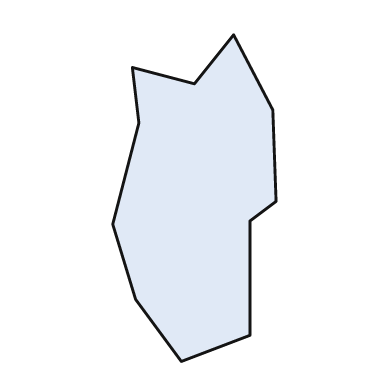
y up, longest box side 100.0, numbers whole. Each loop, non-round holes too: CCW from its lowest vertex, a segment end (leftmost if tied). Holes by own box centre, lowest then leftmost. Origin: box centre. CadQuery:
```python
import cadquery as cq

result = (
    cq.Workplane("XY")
    .moveTo(-4.0, -50.0)
    .lineTo(17.0, -42.0)
    .lineTo(17.0, -7.0)
    .lineTo(25.0, -1.0)
    .lineTo(24.0, 27.0)
    .lineTo(12.0, 50.0)
    .lineTo(0.0, 35.0)
    .lineTo(-19.0, 40.0)
    .lineTo(-17.0, 23.0)
    .lineTo(-25.0, -8.0)
    .lineTo(-18.0, -31.0)
    .close()
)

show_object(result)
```